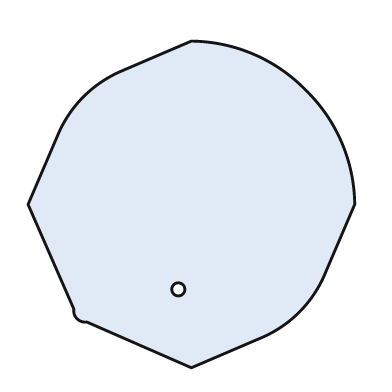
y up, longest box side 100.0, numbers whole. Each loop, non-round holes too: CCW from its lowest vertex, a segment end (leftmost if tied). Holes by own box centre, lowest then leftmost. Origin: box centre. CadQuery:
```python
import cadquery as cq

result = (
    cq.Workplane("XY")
    .moveTo(0.0, -50.0)
    .lineTo(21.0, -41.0)
    .threePointArc((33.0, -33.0), (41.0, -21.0))
    .lineTo(50.0, 0.0)
    .threePointArc((46.0, 19.0), (35.0, 35.0))
    .threePointArc((19.0, 46.0), (0.0, 50.0))
    .lineTo(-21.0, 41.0)
    .threePointArc((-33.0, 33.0), (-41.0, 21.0))
    .lineTo(-50.0, 0.0)
    .lineTo(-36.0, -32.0)
    .threePointArc((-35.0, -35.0), (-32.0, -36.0))
    .close()
    .moveTo(-4.0, -26.0)
    .circle(2.0)
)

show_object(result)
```